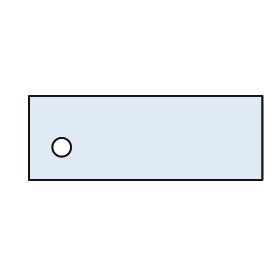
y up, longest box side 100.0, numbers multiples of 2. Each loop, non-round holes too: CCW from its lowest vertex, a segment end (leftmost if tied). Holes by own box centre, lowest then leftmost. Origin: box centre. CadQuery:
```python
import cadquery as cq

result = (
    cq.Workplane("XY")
    .moveTo(-50.0, -18.0)
    .lineTo(50.0, -18.0)
    .lineTo(50.0, 18.0)
    .lineTo(-50.0, 18.0)
    .close()
    .moveTo(-36.0, -4.0)
    .circle(4.0)
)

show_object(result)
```